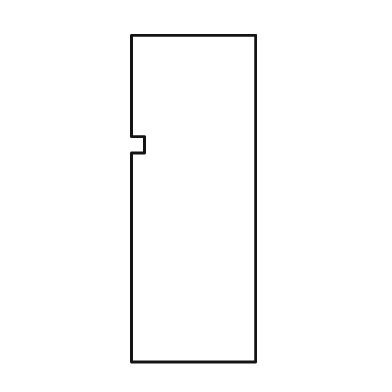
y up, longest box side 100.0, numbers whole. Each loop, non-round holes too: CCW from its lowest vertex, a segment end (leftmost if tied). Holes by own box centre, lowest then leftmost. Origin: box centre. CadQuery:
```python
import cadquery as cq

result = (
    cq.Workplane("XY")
    .moveTo(-19.0, -50.0)
    .lineTo(19.0, -50.0)
    .lineTo(19.0, 50.0)
    .lineTo(-19.0, 50.0)
    .lineTo(-19.0, 19.0)
    .lineTo(-15.0, 19.0)
    .lineTo(-15.0, 14.0)
    .lineTo(-19.0, 14.0)
    .close()
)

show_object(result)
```